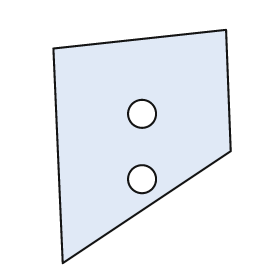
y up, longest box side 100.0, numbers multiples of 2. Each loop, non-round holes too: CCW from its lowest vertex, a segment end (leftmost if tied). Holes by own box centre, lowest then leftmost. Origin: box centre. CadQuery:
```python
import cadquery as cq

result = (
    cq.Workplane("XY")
    .moveTo(-34.0, -50.0)
    .lineTo(38.0, -2.0)
    .lineTo(36.0, 50.0)
    .lineTo(-38.0, 42.0)
    .close()
    .moveTo(0.0, -14.0)
    .circle(6.0)
    .moveTo(0.0, 14.0)
    .circle(6.0)
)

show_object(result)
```